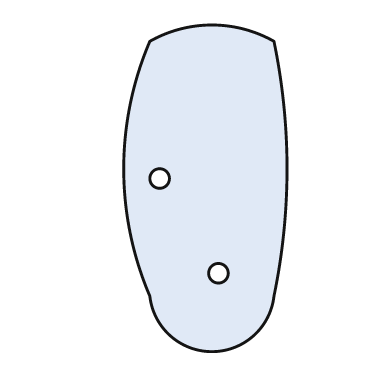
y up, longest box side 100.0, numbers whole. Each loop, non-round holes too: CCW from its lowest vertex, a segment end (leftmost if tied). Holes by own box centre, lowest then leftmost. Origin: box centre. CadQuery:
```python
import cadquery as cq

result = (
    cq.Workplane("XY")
    .moveTo(-17.0, -33.0)
    .threePointArc((2.0, -50.0), (21.0, -33.0))
    .threePointArc((25.0, 6.0), (21.0, 45.0))
    .threePointArc((2.0, 50.0), (-17.0, 45.0))
    .threePointArc((-25.0, 6.0), (-17.0, -33.0))
    .close()
    .moveTo(4.0, -26.0)
    .circle(3.0)
    .moveTo(-14.0, 3.0)
    .circle(3.0)
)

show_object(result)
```